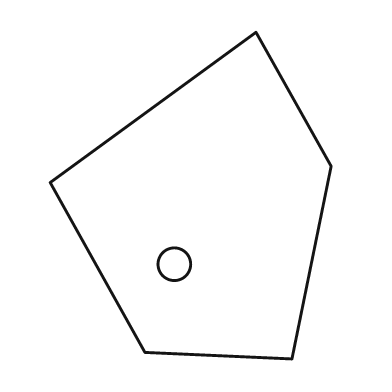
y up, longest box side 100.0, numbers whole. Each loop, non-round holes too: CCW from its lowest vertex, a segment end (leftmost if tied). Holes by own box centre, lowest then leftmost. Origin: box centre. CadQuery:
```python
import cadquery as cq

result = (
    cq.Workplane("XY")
    .moveTo(31.0, -50.0)
    .lineTo(43.0, 9.0)
    .lineTo(20.0, 50.0)
    .lineTo(-43.0, 4.0)
    .lineTo(-14.0, -48.0)
    .close()
    .moveTo(-5.0, -21.0)
    .circle(5.0)
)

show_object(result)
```